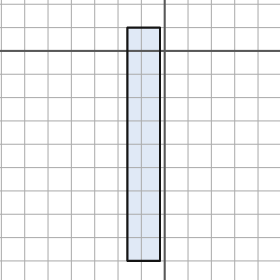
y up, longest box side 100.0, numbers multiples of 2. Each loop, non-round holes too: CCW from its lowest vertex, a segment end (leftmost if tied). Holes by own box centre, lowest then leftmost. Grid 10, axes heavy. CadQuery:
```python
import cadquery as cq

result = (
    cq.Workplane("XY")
    .moveTo(-16.0, -90.0)
    .lineTo(-2.0, -90.0)
    .lineTo(-2.0, 10.0)
    .lineTo(-16.0, 10.0)
    .close()
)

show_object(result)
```